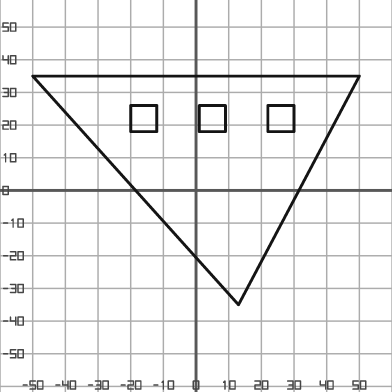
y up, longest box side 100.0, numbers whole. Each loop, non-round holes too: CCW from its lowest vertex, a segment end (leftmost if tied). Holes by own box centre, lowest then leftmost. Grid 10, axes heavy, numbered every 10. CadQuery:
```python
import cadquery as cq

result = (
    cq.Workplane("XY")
    .moveTo(13.0, -35.0)
    .lineTo(50.0, 35.0)
    .lineTo(-50.0, 35.0)
    .close()
    .moveTo(-20.0, 18.0)
    .lineTo(-12.0, 18.0)
    .lineTo(-12.0, 26.0)
    .lineTo(-20.0, 26.0)
    .close()
    .moveTo(1.0, 18.0)
    .lineTo(9.0, 18.0)
    .lineTo(9.0, 26.0)
    .lineTo(1.0, 26.0)
    .close()
    .moveTo(22.0, 18.0)
    .lineTo(30.0, 18.0)
    .lineTo(30.0, 26.0)
    .lineTo(22.0, 26.0)
    .close()
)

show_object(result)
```